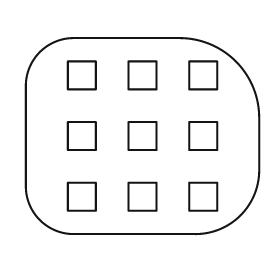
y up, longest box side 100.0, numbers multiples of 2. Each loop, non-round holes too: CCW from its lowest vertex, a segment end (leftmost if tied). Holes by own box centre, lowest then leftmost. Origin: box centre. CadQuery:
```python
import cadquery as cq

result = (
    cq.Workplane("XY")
    .moveTo(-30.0, -42.0)
    .lineTo(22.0, -42.0)
    .threePointArc((42.0, -34.0), (50.0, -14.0))
    .lineTo(50.0, 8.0)
    .threePointArc((40.0, 32.0), (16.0, 42.0))
    .lineTo(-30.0, 42.0)
    .threePointArc((-44.0, 36.0), (-50.0, 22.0))
    .lineTo(-50.0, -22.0)
    .threePointArc((-44.0, -36.0), (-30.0, -42.0))
    .close()
    .moveTo(-32.0, -32.0)
    .lineTo(-20.0, -32.0)
    .lineTo(-20.0, -20.0)
    .lineTo(-32.0, -20.0)
    .close()
    .moveTo(-6.0, -32.0)
    .lineTo(6.0, -32.0)
    .lineTo(6.0, -20.0)
    .lineTo(-6.0, -20.0)
    .close()
    .moveTo(20.0, -32.0)
    .lineTo(32.0, -32.0)
    .lineTo(32.0, -20.0)
    .lineTo(20.0, -20.0)
    .close()
    .moveTo(-32.0, -6.0)
    .lineTo(-20.0, -6.0)
    .lineTo(-20.0, 6.0)
    .lineTo(-32.0, 6.0)
    .close()
    .moveTo(-6.0, -6.0)
    .lineTo(6.0, -6.0)
    .lineTo(6.0, 6.0)
    .lineTo(-6.0, 6.0)
    .close()
    .moveTo(20.0, -6.0)
    .lineTo(32.0, -6.0)
    .lineTo(32.0, 6.0)
    .lineTo(20.0, 6.0)
    .close()
    .moveTo(-32.0, 20.0)
    .lineTo(-20.0, 20.0)
    .lineTo(-20.0, 32.0)
    .lineTo(-32.0, 32.0)
    .close()
    .moveTo(-6.0, 20.0)
    .lineTo(6.0, 20.0)
    .lineTo(6.0, 32.0)
    .lineTo(-6.0, 32.0)
    .close()
    .moveTo(20.0, 20.0)
    .lineTo(32.0, 20.0)
    .lineTo(32.0, 32.0)
    .lineTo(20.0, 32.0)
    .close()
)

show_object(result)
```